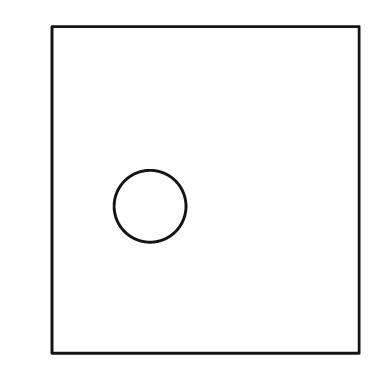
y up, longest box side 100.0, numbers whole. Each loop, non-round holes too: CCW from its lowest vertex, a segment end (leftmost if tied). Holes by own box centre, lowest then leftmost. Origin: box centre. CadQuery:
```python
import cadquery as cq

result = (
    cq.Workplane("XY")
    .moveTo(-47.0, -50.0)
    .lineTo(47.0, -50.0)
    .lineTo(47.0, 50.0)
    .lineTo(-47.0, 50.0)
    .close()
    .moveTo(-17.0, -5.0)
    .circle(11.0)
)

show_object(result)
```